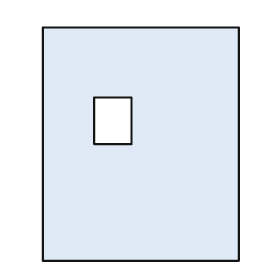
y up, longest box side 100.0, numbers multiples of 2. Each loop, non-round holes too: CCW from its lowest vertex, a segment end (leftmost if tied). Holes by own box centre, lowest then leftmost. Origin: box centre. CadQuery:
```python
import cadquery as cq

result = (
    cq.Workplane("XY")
    .moveTo(-42.0, -50.0)
    .lineTo(42.0, -50.0)
    .lineTo(42.0, 50.0)
    .lineTo(-42.0, 50.0)
    .close()
    .moveTo(-20.0, 0.0)
    .lineTo(-4.0, 0.0)
    .lineTo(-4.0, 20.0)
    .lineTo(-20.0, 20.0)
    .close()
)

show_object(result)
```